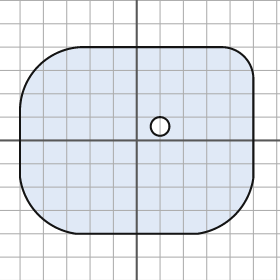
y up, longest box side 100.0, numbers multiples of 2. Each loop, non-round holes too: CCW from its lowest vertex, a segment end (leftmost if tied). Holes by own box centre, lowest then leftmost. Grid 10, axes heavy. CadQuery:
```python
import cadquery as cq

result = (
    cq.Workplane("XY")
    .moveTo(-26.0, -40.0)
    .lineTo(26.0, -40.0)
    .threePointArc((42.0, -32.0), (50.0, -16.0))
    .lineTo(50.0, 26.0)
    .threePointArc((46.0, 36.0), (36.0, 40.0))
    .lineTo(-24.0, 40.0)
    .threePointArc((-42.0, 32.0), (-50.0, 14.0))
    .lineTo(-50.0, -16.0)
    .threePointArc((-42.0, -32.0), (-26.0, -40.0))
    .close()
    .moveTo(10.0, 6.0)
    .circle(4.0)
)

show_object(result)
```